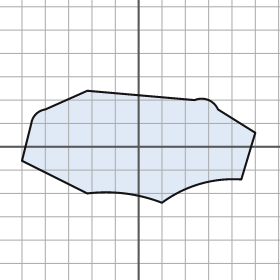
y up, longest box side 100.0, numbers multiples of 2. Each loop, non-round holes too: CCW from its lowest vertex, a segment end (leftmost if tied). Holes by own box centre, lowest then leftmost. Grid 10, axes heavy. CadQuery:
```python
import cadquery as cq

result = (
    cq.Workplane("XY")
    .moveTo(10.0, -24.0)
    .threePointArc((26.0, -16.0), (44.0, -14.0))
    .lineTo(50.0, 6.0)
    .lineTo(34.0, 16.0)
    .threePointArc((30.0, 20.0), (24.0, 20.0))
    .lineTo(-22.0, 24.0)
    .lineTo(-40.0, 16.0)
    .threePointArc((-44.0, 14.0), (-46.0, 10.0))
    .lineTo(-50.0, -6.0)
    .lineTo(-22.0, -20.0)
    .threePointArc((-6.0, -20.0), (10.0, -24.0))
    .close()
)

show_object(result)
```